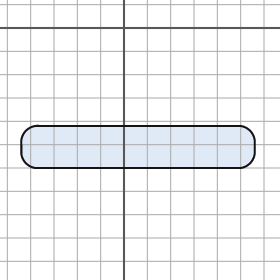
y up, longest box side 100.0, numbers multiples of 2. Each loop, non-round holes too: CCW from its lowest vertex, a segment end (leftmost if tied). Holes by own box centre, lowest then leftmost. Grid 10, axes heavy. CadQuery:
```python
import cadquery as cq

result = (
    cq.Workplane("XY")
    .moveTo(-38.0, -60.0)
    .lineTo(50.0, -60.0)
    .threePointArc((54.0, -58.0), (56.0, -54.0))
    .lineTo(56.0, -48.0)
    .threePointArc((54.0, -44.0), (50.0, -42.0))
    .lineTo(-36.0, -42.0)
    .threePointArc((-42.0, -44.0), (-44.0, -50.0))
    .lineTo(-44.0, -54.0)
    .threePointArc((-42.0, -58.0), (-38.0, -60.0))
    .close()
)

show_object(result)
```